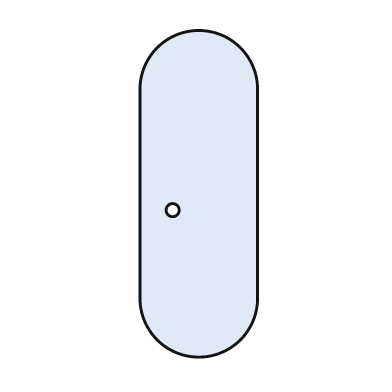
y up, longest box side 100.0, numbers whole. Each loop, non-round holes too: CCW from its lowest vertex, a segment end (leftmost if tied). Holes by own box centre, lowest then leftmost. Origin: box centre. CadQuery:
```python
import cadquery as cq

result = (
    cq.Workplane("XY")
    .moveTo(-18.0, -32.0)
    .threePointArc((0.0, -50.0), (18.0, -32.0))
    .lineTo(18.0, 32.0)
    .threePointArc((0.0, 50.0), (-18.0, 32.0))
    .close()
    .moveTo(-8.0, -5.0)
    .circle(2.0)
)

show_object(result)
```